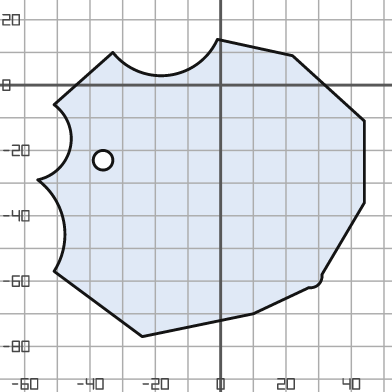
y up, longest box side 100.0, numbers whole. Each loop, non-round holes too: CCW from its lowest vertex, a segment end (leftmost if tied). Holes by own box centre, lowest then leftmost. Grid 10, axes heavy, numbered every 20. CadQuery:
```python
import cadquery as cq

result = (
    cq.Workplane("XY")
    .moveTo(-24.0, -77.0)
    .lineTo(10.0, -70.0)
    .lineTo(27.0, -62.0)
    .threePointArc((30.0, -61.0), (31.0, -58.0))
    .lineTo(44.0, -36.0)
    .lineTo(44.0, -11.0)
    .lineTo(22.0, 9.0)
    .lineTo(-1.0, 14.0)
    .threePointArc((-16.0, 3.0), (-33.0, 10.0))
    .lineTo(-51.0, -6.0)
    .threePointArc((-46.0, -19.0), (-56.0, -29.0))
    .threePointArc((-48.0, -42.0), (-51.0, -57.0))
    .close()
    .moveTo(-36.0, -23.0)
    .circle(3.0)
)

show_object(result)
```